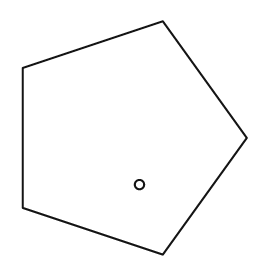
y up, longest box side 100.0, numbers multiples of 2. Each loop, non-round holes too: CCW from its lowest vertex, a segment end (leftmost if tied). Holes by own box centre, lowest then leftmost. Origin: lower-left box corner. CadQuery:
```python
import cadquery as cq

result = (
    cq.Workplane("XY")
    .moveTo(60.0, 0.0)
    .lineTo(96.0, 50.0)
    .lineTo(60.0, 100.0)
    .lineTo(0.0, 80.0)
    .lineTo(0.0, 20.0)
    .close()
    .moveTo(50.0, 30.0)
    .circle(2.0)
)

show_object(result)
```